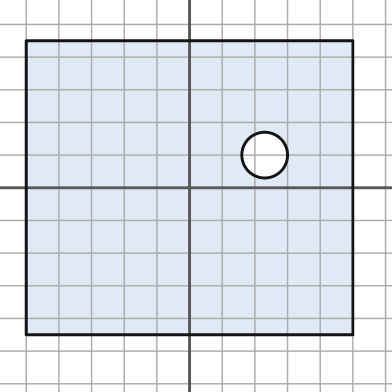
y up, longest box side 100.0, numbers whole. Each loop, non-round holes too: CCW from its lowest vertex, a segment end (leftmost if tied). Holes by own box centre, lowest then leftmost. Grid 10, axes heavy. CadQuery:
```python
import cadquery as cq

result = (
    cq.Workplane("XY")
    .moveTo(-50.0, -45.0)
    .lineTo(50.0, -45.0)
    .lineTo(50.0, 45.0)
    .lineTo(-50.0, 45.0)
    .close()
    .moveTo(23.0, 10.0)
    .circle(7.0)
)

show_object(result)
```